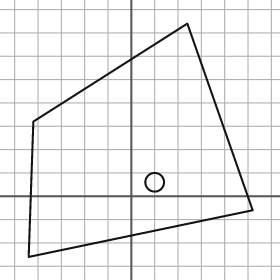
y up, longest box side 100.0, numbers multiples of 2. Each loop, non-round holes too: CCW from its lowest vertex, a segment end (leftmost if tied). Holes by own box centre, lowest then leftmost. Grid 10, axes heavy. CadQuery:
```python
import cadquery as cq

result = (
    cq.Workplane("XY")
    .moveTo(-44.0, -26.0)
    .lineTo(52.0, -6.0)
    .lineTo(24.0, 74.0)
    .lineTo(-42.0, 32.0)
    .close()
    .moveTo(10.0, 6.0)
    .circle(4.0)
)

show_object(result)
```